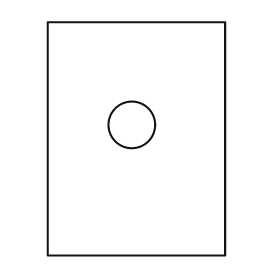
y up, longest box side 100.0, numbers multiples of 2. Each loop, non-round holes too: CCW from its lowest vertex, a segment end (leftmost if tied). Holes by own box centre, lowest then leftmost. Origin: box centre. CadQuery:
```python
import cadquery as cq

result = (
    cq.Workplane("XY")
    .moveTo(-38.0, -50.0)
    .lineTo(38.0, -50.0)
    .lineTo(38.0, 50.0)
    .lineTo(-38.0, 50.0)
    .close()
    .moveTo(-2.0, 6.0)
    .circle(10.0)
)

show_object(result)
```